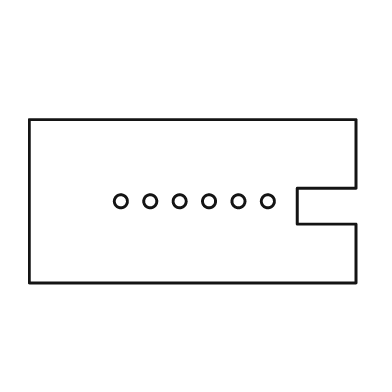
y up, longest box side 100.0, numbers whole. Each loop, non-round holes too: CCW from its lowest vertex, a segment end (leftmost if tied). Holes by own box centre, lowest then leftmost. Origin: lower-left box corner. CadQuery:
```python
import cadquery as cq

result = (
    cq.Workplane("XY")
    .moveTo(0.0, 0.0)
    .lineTo(100.0, 0.0)
    .lineTo(100.0, 18.0)
    .lineTo(82.0, 18.0)
    .lineTo(82.0, 29.0)
    .lineTo(100.0, 29.0)
    .lineTo(100.0, 50.0)
    .lineTo(0.0, 50.0)
    .close()
    .moveTo(28.0, 25.0)
    .circle(2.0)
    .moveTo(37.0, 25.0)
    .circle(2.0)
    .moveTo(46.0, 25.0)
    .circle(2.0)
    .moveTo(55.0, 25.0)
    .circle(2.0)
    .moveTo(64.0, 25.0)
    .circle(2.0)
    .moveTo(73.0, 25.0)
    .circle(2.0)
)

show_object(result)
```